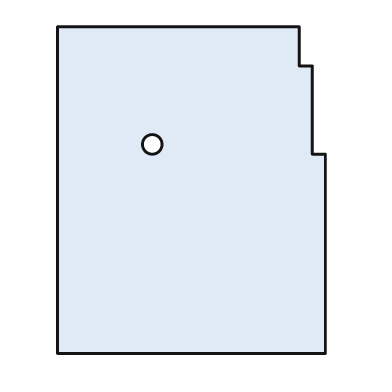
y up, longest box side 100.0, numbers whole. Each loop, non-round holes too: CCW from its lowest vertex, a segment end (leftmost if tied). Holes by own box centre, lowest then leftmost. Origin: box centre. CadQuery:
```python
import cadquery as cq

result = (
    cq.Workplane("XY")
    .moveTo(-41.0, -50.0)
    .lineTo(41.0, -50.0)
    .lineTo(41.0, 11.0)
    .lineTo(37.0, 11.0)
    .lineTo(37.0, 38.0)
    .lineTo(33.0, 38.0)
    .lineTo(33.0, 50.0)
    .lineTo(-41.0, 50.0)
    .close()
    .moveTo(-12.0, 14.0)
    .circle(3.0)
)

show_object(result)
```